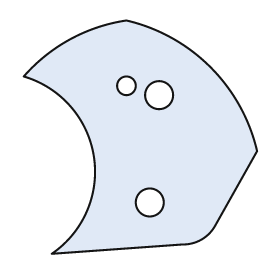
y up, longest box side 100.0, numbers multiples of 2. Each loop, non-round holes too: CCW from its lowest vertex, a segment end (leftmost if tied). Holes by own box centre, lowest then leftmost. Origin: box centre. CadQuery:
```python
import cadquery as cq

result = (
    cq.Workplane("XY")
    .moveTo(-38.0, -50.0)
    .lineTo(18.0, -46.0)
    .threePointArc((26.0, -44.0), (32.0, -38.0))
    .lineTo(50.0, -6.0)
    .threePointArc((30.0, 30.0), (-6.0, 50.0))
    .threePointArc((-30.0, 42.0), (-50.0, 26.0))
    .threePointArc((-20.0, -8.0), (-38.0, -50.0))
    .close()
    .moveTo(4.0, -28.0)
    .circle(6.0)
    .moveTo(8.0, 18.0)
    .circle(6.0)
    .moveTo(-6.0, 22.0)
    .circle(4.0)
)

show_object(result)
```